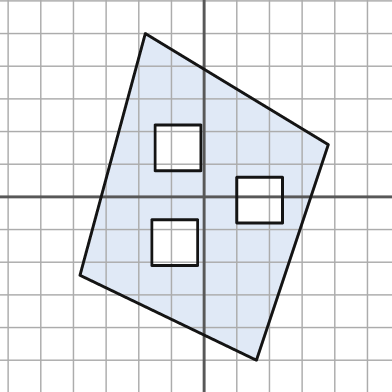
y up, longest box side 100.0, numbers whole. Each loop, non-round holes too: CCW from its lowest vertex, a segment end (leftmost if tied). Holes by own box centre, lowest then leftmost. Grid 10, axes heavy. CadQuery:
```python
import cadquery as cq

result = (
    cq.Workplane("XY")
    .moveTo(16.0, -50.0)
    .lineTo(38.0, 16.0)
    .lineTo(-18.0, 50.0)
    .lineTo(-38.0, -24.0)
    .close()
    .moveTo(-16.0, -21.0)
    .lineTo(-2.0, -21.0)
    .lineTo(-2.0, -7.0)
    .lineTo(-16.0, -7.0)
    .close()
    .moveTo(10.0, -8.0)
    .lineTo(24.0, -8.0)
    .lineTo(24.0, 6.0)
    .lineTo(10.0, 6.0)
    .close()
    .moveTo(-15.0, 8.0)
    .lineTo(-1.0, 8.0)
    .lineTo(-1.0, 22.0)
    .lineTo(-15.0, 22.0)
    .close()
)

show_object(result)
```